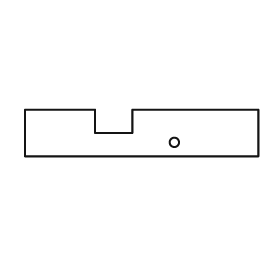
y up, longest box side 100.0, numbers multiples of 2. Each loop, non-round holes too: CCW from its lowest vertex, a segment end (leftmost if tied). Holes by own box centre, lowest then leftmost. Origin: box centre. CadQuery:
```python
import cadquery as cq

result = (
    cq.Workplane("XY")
    .moveTo(-50.0, -10.0)
    .lineTo(50.0, -10.0)
    .lineTo(50.0, 10.0)
    .lineTo(-4.0, 10.0)
    .lineTo(-4.0, 0.0)
    .lineTo(-20.0, 0.0)
    .lineTo(-20.0, 10.0)
    .lineTo(-50.0, 10.0)
    .close()
    .moveTo(14.0, -4.0)
    .circle(2.0)
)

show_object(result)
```